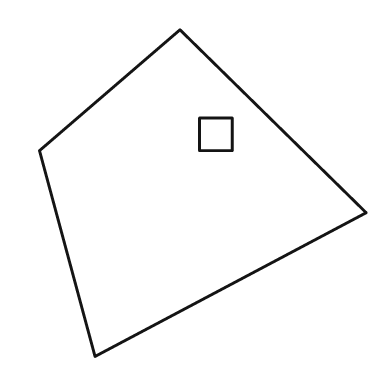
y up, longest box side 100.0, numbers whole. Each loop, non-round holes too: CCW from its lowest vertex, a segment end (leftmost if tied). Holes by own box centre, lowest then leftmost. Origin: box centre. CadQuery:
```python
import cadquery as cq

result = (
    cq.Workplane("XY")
    .moveTo(-33.0, -50.0)
    .lineTo(50.0, -6.0)
    .lineTo(-7.0, 50.0)
    .lineTo(-50.0, 13.0)
    .close()
    .moveTo(-1.0, 13.0)
    .lineTo(9.0, 13.0)
    .lineTo(9.0, 23.0)
    .lineTo(-1.0, 23.0)
    .close()
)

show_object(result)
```